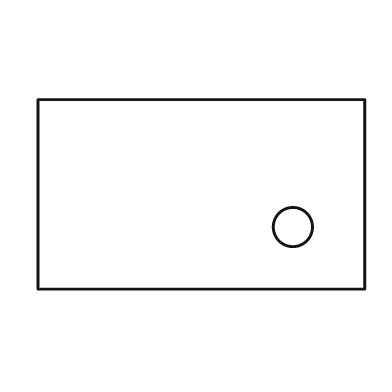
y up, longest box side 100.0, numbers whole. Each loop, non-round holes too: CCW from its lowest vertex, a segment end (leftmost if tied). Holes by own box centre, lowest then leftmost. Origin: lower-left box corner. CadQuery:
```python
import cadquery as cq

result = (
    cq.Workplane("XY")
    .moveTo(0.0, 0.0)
    .lineTo(100.0, 0.0)
    .lineTo(100.0, 58.0)
    .lineTo(0.0, 58.0)
    .close()
    .moveTo(78.0, 19.0)
    .circle(6.0)
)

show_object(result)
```